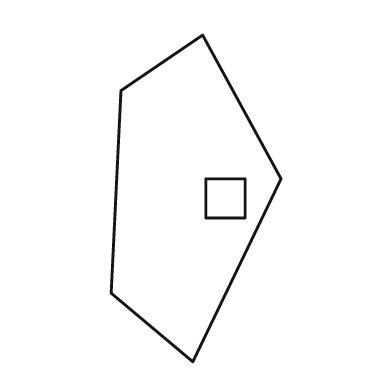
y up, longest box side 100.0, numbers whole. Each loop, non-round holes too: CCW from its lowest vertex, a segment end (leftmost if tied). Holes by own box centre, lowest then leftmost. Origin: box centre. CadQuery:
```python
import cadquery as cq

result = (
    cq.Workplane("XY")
    .moveTo(-1.0, -50.0)
    .lineTo(26.0, 6.0)
    .lineTo(2.0, 50.0)
    .lineTo(-23.0, 33.0)
    .lineTo(-26.0, -29.0)
    .close()
    .moveTo(3.0, -6.0)
    .lineTo(15.0, -6.0)
    .lineTo(15.0, 6.0)
    .lineTo(3.0, 6.0)
    .close()
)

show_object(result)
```